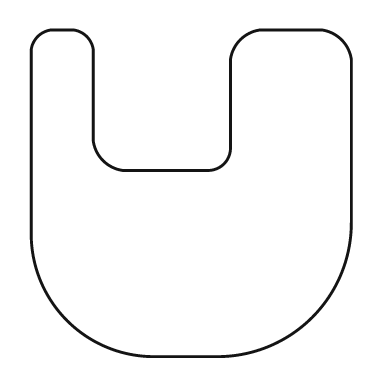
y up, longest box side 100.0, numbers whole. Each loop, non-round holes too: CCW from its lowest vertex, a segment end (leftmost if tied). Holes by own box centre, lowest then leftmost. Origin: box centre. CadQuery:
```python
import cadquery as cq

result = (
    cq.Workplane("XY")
    .moveTo(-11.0, -50.0)
    .lineTo(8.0, -50.0)
    .threePointArc((37.0, -38.0), (49.0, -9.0))
    .lineTo(49.0, 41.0)
    .threePointArc((46.0, 47.0), (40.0, 50.0))
    .lineTo(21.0, 50.0)
    .threePointArc((15.0, 47.0), (12.0, 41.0))
    .lineTo(12.0, 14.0)
    .threePointArc((10.0, 9.0), (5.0, 7.0))
    .lineTo(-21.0, 7.0)
    .threePointArc((-27.0, 10.0), (-30.0, 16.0))
    .lineTo(-30.0, 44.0)
    .threePointArc((-32.0, 48.0), (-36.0, 50.0))
    .lineTo(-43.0, 50.0)
    .threePointArc((-47.0, 48.0), (-49.0, 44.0))
    .lineTo(-49.0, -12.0)
    .threePointArc((-38.0, -39.0), (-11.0, -50.0))
    .close()
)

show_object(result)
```